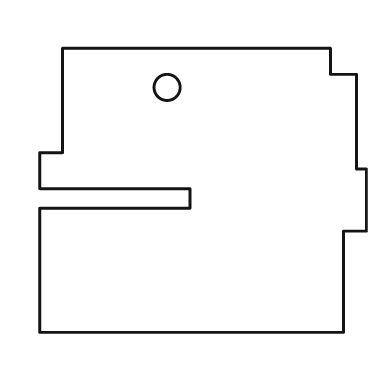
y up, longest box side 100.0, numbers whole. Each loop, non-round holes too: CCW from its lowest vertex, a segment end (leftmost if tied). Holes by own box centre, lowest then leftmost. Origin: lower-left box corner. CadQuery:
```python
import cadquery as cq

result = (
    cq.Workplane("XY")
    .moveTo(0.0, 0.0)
    .lineTo(93.0, 0.0)
    .lineTo(93.0, 31.0)
    .lineTo(100.0, 31.0)
    .lineTo(100.0, 50.0)
    .lineTo(97.0, 50.0)
    .lineTo(97.0, 79.0)
    .lineTo(89.0, 79.0)
    .lineTo(89.0, 87.0)
    .lineTo(7.0, 87.0)
    .lineTo(7.0, 55.0)
    .lineTo(0.0, 55.0)
    .lineTo(0.0, 44.0)
    .lineTo(46.0, 44.0)
    .lineTo(46.0, 38.0)
    .lineTo(0.0, 38.0)
    .close()
    .moveTo(39.0, 75.0)
    .circle(4.0)
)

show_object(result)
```